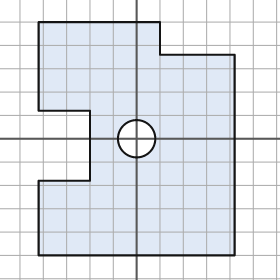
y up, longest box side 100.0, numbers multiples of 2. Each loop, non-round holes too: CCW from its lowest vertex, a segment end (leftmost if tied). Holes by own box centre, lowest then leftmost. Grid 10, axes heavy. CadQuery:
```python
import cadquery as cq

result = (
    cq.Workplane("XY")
    .moveTo(-42.0, -50.0)
    .lineTo(42.0, -50.0)
    .lineTo(42.0, 36.0)
    .lineTo(10.0, 36.0)
    .lineTo(10.0, 50.0)
    .lineTo(-42.0, 50.0)
    .lineTo(-42.0, 12.0)
    .lineTo(-20.0, 12.0)
    .lineTo(-20.0, -18.0)
    .lineTo(-42.0, -18.0)
    .close()
    .moveTo(0.0, 0.0)
    .circle(8.0)
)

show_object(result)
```